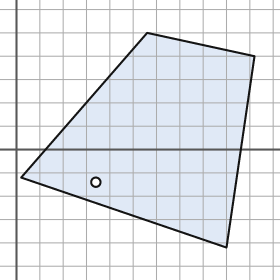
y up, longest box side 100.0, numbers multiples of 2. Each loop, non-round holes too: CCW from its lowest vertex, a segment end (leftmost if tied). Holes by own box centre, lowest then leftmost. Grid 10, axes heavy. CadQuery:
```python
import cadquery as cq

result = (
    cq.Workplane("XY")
    .moveTo(90.0, -42.0)
    .lineTo(102.0, 40.0)
    .lineTo(56.0, 50.0)
    .lineTo(2.0, -12.0)
    .close()
    .moveTo(34.0, -14.0)
    .circle(2.0)
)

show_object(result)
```